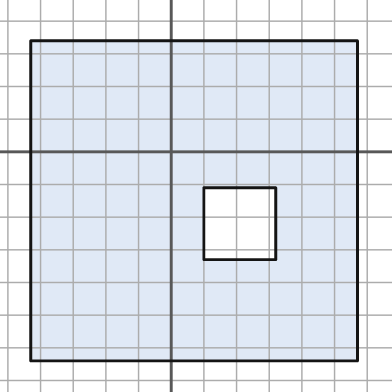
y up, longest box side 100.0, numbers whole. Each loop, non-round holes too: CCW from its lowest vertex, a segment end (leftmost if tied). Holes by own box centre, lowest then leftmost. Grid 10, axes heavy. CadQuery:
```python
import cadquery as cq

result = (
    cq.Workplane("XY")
    .moveTo(-43.0, -64.0)
    .lineTo(57.0, -64.0)
    .lineTo(57.0, 34.0)
    .lineTo(-43.0, 34.0)
    .close()
    .moveTo(10.0, -33.0)
    .lineTo(32.0, -33.0)
    .lineTo(32.0, -11.0)
    .lineTo(10.0, -11.0)
    .close()
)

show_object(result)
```